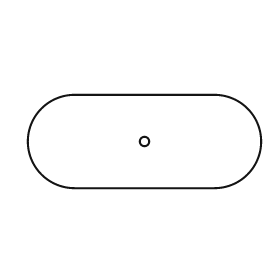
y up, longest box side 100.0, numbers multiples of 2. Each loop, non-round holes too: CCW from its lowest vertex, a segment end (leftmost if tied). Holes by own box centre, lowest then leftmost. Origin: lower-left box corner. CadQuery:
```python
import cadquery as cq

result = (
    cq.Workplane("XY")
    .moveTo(20.0, 0.0)
    .lineTo(80.0, 0.0)
    .threePointArc((100.0, 20.0), (80.0, 40.0))
    .lineTo(20.0, 40.0)
    .threePointArc((0.0, 20.0), (20.0, 0.0))
    .close()
    .moveTo(50.0, 20.0)
    .circle(2.0)
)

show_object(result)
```